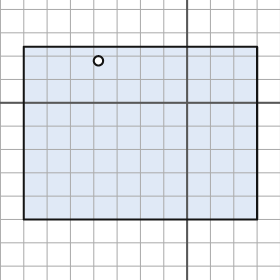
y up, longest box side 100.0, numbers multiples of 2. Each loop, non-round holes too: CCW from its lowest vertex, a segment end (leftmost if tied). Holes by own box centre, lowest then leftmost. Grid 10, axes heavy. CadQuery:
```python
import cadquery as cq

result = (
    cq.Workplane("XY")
    .moveTo(-70.0, -50.0)
    .lineTo(30.0, -50.0)
    .lineTo(30.0, 24.0)
    .lineTo(-70.0, 24.0)
    .close()
    .moveTo(-38.0, 18.0)
    .circle(2.0)
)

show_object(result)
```